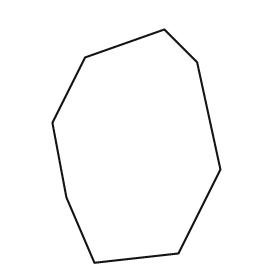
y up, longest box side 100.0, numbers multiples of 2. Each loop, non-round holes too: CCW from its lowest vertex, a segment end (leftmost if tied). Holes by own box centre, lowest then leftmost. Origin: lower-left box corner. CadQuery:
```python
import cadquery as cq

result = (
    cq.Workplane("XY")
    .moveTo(18.0, 0.0)
    .lineTo(54.0, 4.0)
    .lineTo(72.0, 40.0)
    .lineTo(62.0, 86.0)
    .lineTo(48.0, 100.0)
    .lineTo(14.0, 88.0)
    .lineTo(0.0, 60.0)
    .lineTo(6.0, 28.0)
    .close()
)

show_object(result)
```